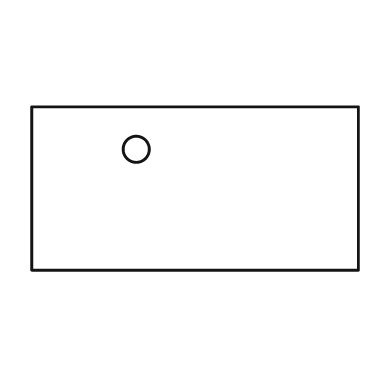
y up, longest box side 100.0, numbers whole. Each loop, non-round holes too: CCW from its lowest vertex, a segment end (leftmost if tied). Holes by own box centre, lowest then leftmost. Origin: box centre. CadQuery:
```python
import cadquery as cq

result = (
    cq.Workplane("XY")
    .moveTo(-50.0, -25.0)
    .lineTo(50.0, -25.0)
    .lineTo(50.0, 25.0)
    .lineTo(-50.0, 25.0)
    .close()
    .moveTo(-18.0, 12.0)
    .circle(4.0)
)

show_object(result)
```